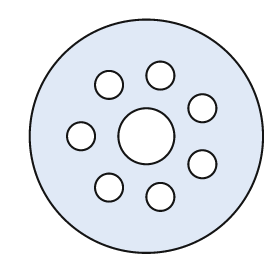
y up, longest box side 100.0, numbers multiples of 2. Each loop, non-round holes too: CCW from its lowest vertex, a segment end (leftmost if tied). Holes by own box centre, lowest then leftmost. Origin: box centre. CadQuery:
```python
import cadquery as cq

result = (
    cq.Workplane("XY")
    .moveTo(0.0, 0.0)
    .circle(50.0)
    .moveTo(6.0, -26.0)
    .circle(6.0)
    .moveTo(-16.0, -22.0)
    .circle(6.0)
    .moveTo(24.0, -12.0)
    .circle(6.0)
    .moveTo(-28.0, 0.0)
    .circle(6.0)
    .moveTo(0.0, 0.0)
    .circle(12.0)
    .moveTo(24.0, 12.0)
    .circle(6.0)
    .moveTo(-16.0, 22.0)
    .circle(6.0)
    .moveTo(6.0, 26.0)
    .circle(6.0)
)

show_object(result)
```